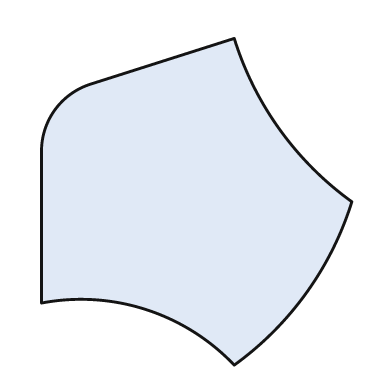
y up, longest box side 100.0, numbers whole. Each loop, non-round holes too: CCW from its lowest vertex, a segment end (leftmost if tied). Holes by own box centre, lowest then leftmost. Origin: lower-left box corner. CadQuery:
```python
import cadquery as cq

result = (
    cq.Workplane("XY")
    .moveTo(59.0, 0.0)
    .threePointArc((81.0, 22.0), (95.0, 50.0))
    .threePointArc((73.0, 72.0), (59.0, 100.0))
    .lineTo(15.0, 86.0)
    .threePointArc((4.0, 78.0), (0.0, 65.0))
    .lineTo(0.0, 19.0)
    .threePointArc((32.0, 17.0), (59.0, 0.0))
    .close()
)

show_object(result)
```